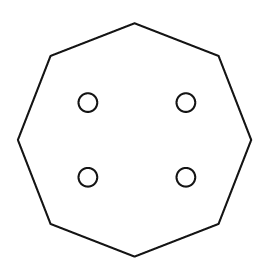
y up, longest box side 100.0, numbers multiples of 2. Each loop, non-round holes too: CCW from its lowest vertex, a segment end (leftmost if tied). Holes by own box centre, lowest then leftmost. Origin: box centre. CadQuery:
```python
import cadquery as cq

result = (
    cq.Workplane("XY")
    .moveTo(0.0, -50.0)
    .lineTo(36.0, -36.0)
    .lineTo(50.0, 0.0)
    .lineTo(36.0, 36.0)
    .lineTo(0.0, 50.0)
    .lineTo(-36.0, 36.0)
    .lineTo(-50.0, 0.0)
    .lineTo(-36.0, -36.0)
    .close()
    .moveTo(-20.0, -16.0)
    .circle(4.0)
    .moveTo(22.0, -16.0)
    .circle(4.0)
    .moveTo(-20.0, 16.0)
    .circle(4.0)
    .moveTo(22.0, 16.0)
    .circle(4.0)
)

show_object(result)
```